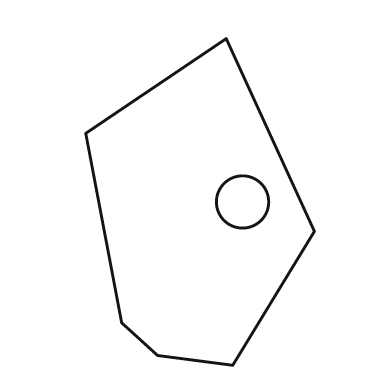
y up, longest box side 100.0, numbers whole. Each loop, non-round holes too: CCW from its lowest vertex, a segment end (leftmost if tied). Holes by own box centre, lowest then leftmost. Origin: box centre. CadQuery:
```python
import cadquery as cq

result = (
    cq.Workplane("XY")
    .moveTo(10.0, -50.0)
    .lineTo(35.0, -9.0)
    .lineTo(8.0, 50.0)
    .lineTo(-35.0, 21.0)
    .lineTo(-24.0, -37.0)
    .lineTo(-13.0, -47.0)
    .close()
    .moveTo(13.0, 0.0)
    .circle(8.0)
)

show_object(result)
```